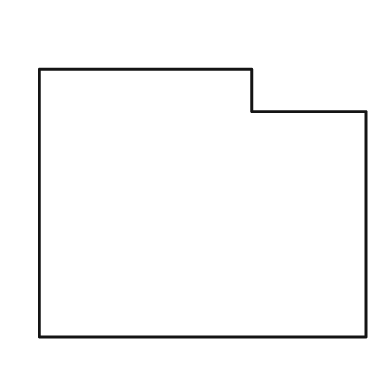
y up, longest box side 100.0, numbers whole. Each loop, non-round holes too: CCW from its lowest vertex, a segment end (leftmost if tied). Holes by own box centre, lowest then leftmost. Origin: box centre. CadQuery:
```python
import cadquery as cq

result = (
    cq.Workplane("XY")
    .moveTo(-50.0, -41.0)
    .lineTo(50.0, -41.0)
    .lineTo(50.0, 28.0)
    .lineTo(15.0, 28.0)
    .lineTo(15.0, 41.0)
    .lineTo(-50.0, 41.0)
    .close()
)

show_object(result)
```